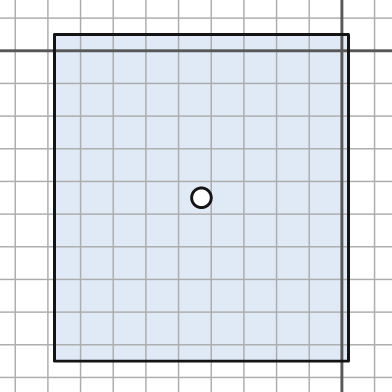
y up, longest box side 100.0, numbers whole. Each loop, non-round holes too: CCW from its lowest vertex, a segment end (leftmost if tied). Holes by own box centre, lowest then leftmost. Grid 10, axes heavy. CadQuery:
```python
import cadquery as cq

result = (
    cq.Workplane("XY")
    .moveTo(-88.0, -95.0)
    .lineTo(2.0, -95.0)
    .lineTo(2.0, 5.0)
    .lineTo(-88.0, 5.0)
    .close()
    .moveTo(-43.0, -45.0)
    .circle(3.0)
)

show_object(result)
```